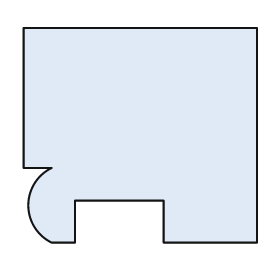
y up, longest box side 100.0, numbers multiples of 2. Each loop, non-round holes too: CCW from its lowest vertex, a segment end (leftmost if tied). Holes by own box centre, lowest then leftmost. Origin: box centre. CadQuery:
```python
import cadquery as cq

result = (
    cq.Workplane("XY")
    .moveTo(-38.0, -46.0)
    .lineTo(-28.0, -46.0)
    .lineTo(-28.0, -28.0)
    .lineTo(10.0, -28.0)
    .lineTo(10.0, -46.0)
    .lineTo(50.0, -46.0)
    .lineTo(50.0, 46.0)
    .lineTo(-50.0, 46.0)
    .lineTo(-50.0, -14.0)
    .lineTo(-38.0, -14.0)
    .threePointArc((-48.0, -30.0), (-38.0, -46.0))
    .close()
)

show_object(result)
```